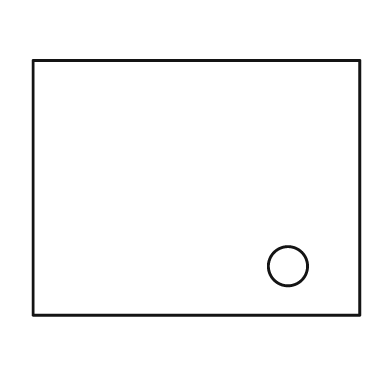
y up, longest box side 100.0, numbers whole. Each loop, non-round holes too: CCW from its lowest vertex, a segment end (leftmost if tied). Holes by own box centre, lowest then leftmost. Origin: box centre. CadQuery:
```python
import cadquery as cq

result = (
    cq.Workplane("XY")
    .moveTo(-50.0, -39.0)
    .lineTo(50.0, -39.0)
    .lineTo(50.0, 39.0)
    .lineTo(-50.0, 39.0)
    .close()
    .moveTo(28.0, -24.0)
    .circle(6.0)
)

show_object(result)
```